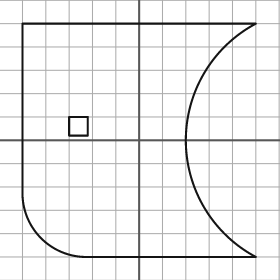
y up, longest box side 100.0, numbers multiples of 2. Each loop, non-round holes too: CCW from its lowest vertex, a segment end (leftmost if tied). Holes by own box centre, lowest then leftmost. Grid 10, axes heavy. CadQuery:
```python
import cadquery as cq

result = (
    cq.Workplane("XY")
    .moveTo(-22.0, -50.0)
    .lineTo(50.0, -50.0)
    .threePointArc((20.0, 0.0), (50.0, 50.0))
    .lineTo(-50.0, 50.0)
    .lineTo(-50.0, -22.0)
    .threePointArc((-42.0, -42.0), (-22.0, -50.0))
    .close()
    .moveTo(-30.0, 2.0)
    .lineTo(-22.0, 2.0)
    .lineTo(-22.0, 10.0)
    .lineTo(-30.0, 10.0)
    .close()
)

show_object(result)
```